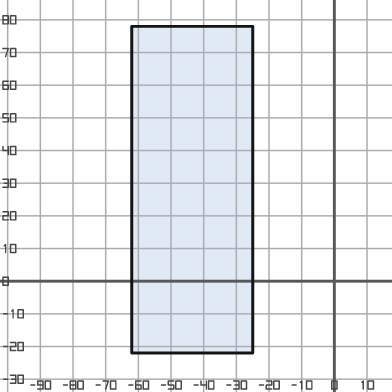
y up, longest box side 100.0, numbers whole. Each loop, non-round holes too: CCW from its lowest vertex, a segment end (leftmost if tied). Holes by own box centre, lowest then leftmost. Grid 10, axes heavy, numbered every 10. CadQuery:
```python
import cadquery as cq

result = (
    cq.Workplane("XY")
    .moveTo(-62.0, -22.0)
    .lineTo(-25.0, -22.0)
    .lineTo(-25.0, 78.0)
    .lineTo(-62.0, 78.0)
    .close()
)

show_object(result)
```